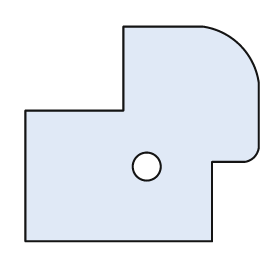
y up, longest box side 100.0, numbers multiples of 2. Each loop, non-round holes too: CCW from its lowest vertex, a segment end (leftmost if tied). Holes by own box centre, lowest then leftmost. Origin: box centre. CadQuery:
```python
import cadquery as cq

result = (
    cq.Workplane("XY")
    .moveTo(-50.0, -46.0)
    .lineTo(30.0, -46.0)
    .lineTo(30.0, -12.0)
    .lineTo(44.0, -12.0)
    .threePointArc((48.0, -10.0), (50.0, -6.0))
    .lineTo(50.0, 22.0)
    .threePointArc((42.0, 38.0), (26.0, 46.0))
    .lineTo(-8.0, 46.0)
    .lineTo(-8.0, 10.0)
    .lineTo(-50.0, 10.0)
    .close()
    .moveTo(2.0, -14.0)
    .circle(6.0)
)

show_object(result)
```